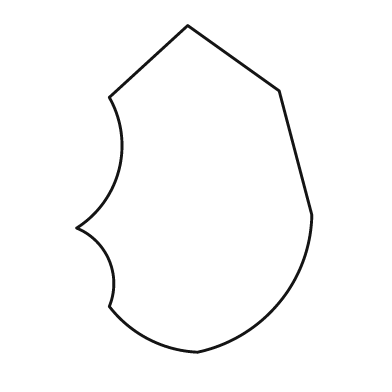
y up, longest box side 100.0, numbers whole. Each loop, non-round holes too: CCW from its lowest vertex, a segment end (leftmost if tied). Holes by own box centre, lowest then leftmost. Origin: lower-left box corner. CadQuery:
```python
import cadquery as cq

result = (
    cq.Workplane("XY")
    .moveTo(37.0, 0.0)
    .threePointArc((50.0, 5.0), (61.0, 14.0))
    .threePointArc((69.0, 27.0), (72.0, 42.0))
    .lineTo(62.0, 80.0)
    .lineTo(34.0, 100.0)
    .lineTo(10.0, 78.0)
    .threePointArc((13.0, 56.0), (0.0, 38.0))
    .threePointArc((10.0, 28.0), (10.0, 14.0))
    .threePointArc((22.0, 4.0), (37.0, 0.0))
    .close()
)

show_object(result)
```